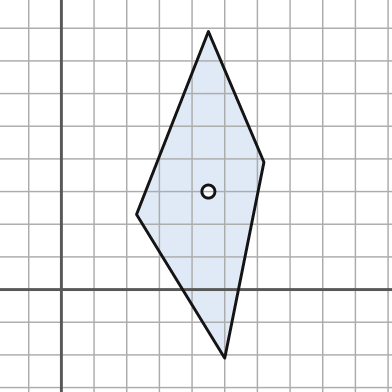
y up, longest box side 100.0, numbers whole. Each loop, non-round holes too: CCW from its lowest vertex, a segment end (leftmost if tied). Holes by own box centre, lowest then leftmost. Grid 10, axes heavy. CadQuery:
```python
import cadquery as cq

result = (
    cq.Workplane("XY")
    .moveTo(50.0, -21.0)
    .lineTo(62.0, 39.0)
    .lineTo(45.0, 79.0)
    .lineTo(23.0, 23.0)
    .close()
    .moveTo(45.0, 30.0)
    .circle(2.0)
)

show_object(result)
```